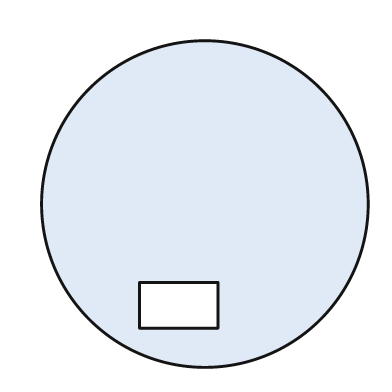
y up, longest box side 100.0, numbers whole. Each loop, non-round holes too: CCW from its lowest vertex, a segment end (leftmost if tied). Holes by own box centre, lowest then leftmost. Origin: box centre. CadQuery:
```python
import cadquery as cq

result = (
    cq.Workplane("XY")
    .moveTo(0.0, 0.0)
    .circle(50.0)
    .moveTo(-20.0, -38.0)
    .lineTo(4.0, -38.0)
    .lineTo(4.0, -24.0)
    .lineTo(-20.0, -24.0)
    .close()
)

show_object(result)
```